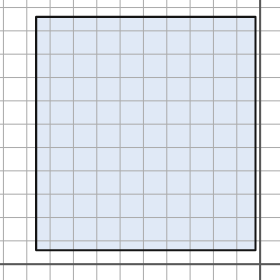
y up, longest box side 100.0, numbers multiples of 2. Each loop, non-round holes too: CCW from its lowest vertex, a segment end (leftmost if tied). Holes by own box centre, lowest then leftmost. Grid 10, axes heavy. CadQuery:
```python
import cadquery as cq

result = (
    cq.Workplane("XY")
    .moveTo(-96.0, 6.0)
    .lineTo(-2.0, 6.0)
    .lineTo(-2.0, 106.0)
    .lineTo(-96.0, 106.0)
    .close()
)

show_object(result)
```